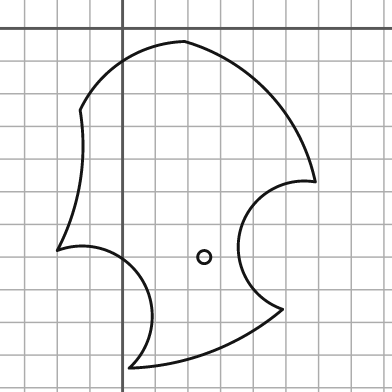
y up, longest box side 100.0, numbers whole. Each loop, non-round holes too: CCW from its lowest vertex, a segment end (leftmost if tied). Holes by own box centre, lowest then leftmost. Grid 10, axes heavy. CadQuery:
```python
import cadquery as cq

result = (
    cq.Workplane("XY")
    .moveTo(2.0, -104.0)
    .threePointArc((27.0, -99.0), (49.0, -86.0))
    .threePointArc((36.0, -62.0), (59.0, -47.0))
    .threePointArc((45.0, -20.0), (19.0, -4.0))
    .threePointArc((0.0, -10.0), (-13.0, -25.0))
    .threePointArc((-13.0, -47.0), (-20.0, -68.0))
    .threePointArc((6.0, -77.0), (2.0, -104.0))
    .close()
    .moveTo(25.0, -70.0)
    .circle(2.0)
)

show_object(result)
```